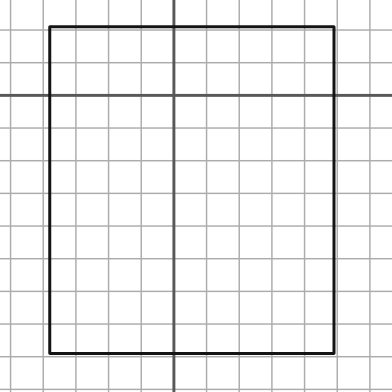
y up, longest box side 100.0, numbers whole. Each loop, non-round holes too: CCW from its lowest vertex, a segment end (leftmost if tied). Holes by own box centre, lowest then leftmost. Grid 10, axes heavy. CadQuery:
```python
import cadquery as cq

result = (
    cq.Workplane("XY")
    .moveTo(-38.0, -79.0)
    .lineTo(49.0, -79.0)
    .lineTo(49.0, 21.0)
    .lineTo(-38.0, 21.0)
    .close()
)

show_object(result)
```